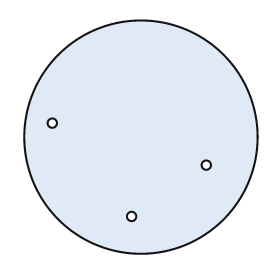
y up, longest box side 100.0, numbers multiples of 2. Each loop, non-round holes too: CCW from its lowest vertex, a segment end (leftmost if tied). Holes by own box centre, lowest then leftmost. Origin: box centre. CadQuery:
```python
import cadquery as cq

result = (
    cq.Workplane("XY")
    .moveTo(0.0, 0.0)
    .circle(50.0)
    .moveTo(-4.0, -34.0)
    .circle(2.0)
    .moveTo(28.0, -12.0)
    .circle(2.0)
    .moveTo(-38.0, 6.0)
    .circle(2.0)
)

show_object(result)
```